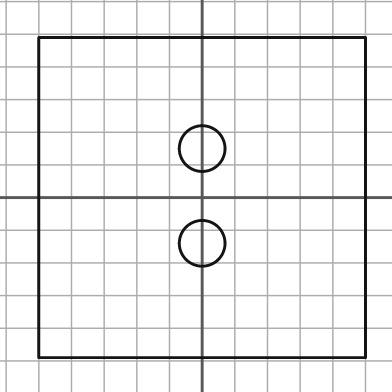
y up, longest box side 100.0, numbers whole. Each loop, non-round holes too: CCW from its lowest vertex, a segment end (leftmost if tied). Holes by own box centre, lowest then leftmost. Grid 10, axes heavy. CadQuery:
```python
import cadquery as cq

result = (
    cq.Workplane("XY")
    .moveTo(-50.0, -49.0)
    .lineTo(50.0, -49.0)
    .lineTo(50.0, 49.0)
    .lineTo(-50.0, 49.0)
    .close()
    .moveTo(0.0, -14.0)
    .circle(7.0)
    .moveTo(0.0, 15.0)
    .circle(7.0)
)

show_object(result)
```